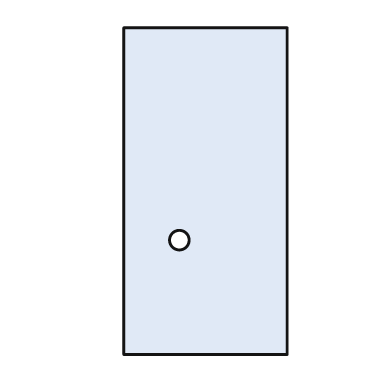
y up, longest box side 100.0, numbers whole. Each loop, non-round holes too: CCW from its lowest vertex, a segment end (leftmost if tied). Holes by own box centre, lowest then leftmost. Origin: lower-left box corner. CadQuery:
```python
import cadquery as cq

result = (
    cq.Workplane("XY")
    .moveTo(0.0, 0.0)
    .lineTo(50.0, 0.0)
    .lineTo(50.0, 100.0)
    .lineTo(0.0, 100.0)
    .close()
    .moveTo(17.0, 35.0)
    .circle(3.0)
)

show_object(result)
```